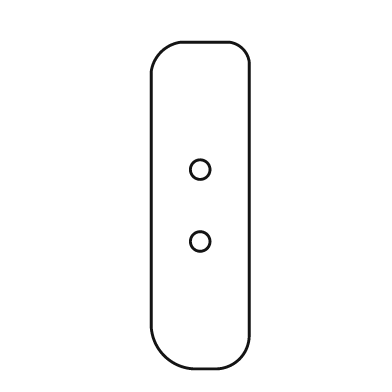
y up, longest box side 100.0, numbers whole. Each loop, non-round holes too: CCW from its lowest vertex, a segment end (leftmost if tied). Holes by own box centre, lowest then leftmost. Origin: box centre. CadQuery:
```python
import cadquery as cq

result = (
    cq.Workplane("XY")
    .moveTo(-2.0, -50.0)
    .lineTo(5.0, -50.0)
    .threePointArc((12.0, -47.0), (15.0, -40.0))
    .lineTo(15.0, 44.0)
    .threePointArc((13.0, 48.0), (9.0, 50.0))
    .lineTo(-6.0, 50.0)
    .threePointArc((-12.0, 47.0), (-15.0, 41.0))
    .lineTo(-15.0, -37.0)
    .threePointArc((-11.0, -46.0), (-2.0, -50.0))
    .close()
    .moveTo(0.0, -11.0)
    .circle(3.0)
    .moveTo(0.0, 11.0)
    .circle(3.0)
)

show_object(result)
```